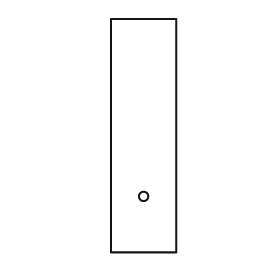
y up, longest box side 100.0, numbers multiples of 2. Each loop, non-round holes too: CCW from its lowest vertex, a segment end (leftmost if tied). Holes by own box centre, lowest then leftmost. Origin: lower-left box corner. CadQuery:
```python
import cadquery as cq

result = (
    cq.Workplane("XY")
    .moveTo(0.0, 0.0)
    .lineTo(28.0, 0.0)
    .lineTo(28.0, 100.0)
    .lineTo(0.0, 100.0)
    .close()
    .moveTo(14.0, 24.0)
    .circle(2.0)
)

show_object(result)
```